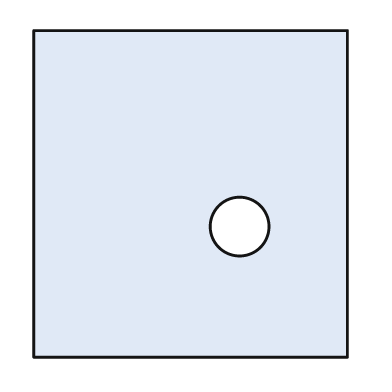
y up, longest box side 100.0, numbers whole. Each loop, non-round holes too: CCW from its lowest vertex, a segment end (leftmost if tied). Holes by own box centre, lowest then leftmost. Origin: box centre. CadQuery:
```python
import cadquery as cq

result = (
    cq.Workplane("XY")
    .moveTo(-48.0, -50.0)
    .lineTo(48.0, -50.0)
    .lineTo(48.0, 50.0)
    .lineTo(-48.0, 50.0)
    .close()
    .moveTo(15.0, -10.0)
    .circle(9.0)
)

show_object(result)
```